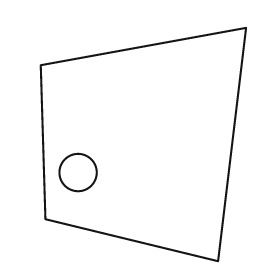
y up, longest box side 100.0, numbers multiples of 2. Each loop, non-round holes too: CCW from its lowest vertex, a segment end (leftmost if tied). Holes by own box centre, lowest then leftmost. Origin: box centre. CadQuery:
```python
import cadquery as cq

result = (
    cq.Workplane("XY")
    .moveTo(32.0, -50.0)
    .lineTo(44.0, 50.0)
    .lineTo(-44.0, 34.0)
    .lineTo(-42.0, -32.0)
    .close()
    .moveTo(-28.0, -12.0)
    .circle(8.0)
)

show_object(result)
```